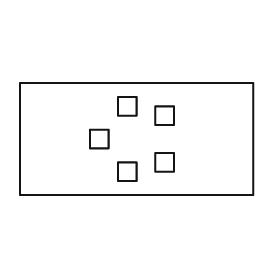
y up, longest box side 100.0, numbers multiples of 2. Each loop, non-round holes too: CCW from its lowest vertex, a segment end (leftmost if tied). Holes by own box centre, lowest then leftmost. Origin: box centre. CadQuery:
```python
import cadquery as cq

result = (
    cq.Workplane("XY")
    .moveTo(-50.0, -24.0)
    .lineTo(50.0, -24.0)
    .lineTo(50.0, 24.0)
    .lineTo(-50.0, 24.0)
    .close()
    .moveTo(-8.0, -18.0)
    .lineTo(0.0, -18.0)
    .lineTo(0.0, -10.0)
    .lineTo(-8.0, -10.0)
    .close()
    .moveTo(8.0, -14.0)
    .lineTo(16.0, -14.0)
    .lineTo(16.0, -6.0)
    .lineTo(8.0, -6.0)
    .close()
    .moveTo(-20.0, -4.0)
    .lineTo(-12.0, -4.0)
    .lineTo(-12.0, 4.0)
    .lineTo(-20.0, 4.0)
    .close()
    .moveTo(8.0, 6.0)
    .lineTo(16.0, 6.0)
    .lineTo(16.0, 14.0)
    .lineTo(8.0, 14.0)
    .close()
    .moveTo(-8.0, 10.0)
    .lineTo(0.0, 10.0)
    .lineTo(0.0, 18.0)
    .lineTo(-8.0, 18.0)
    .close()
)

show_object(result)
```